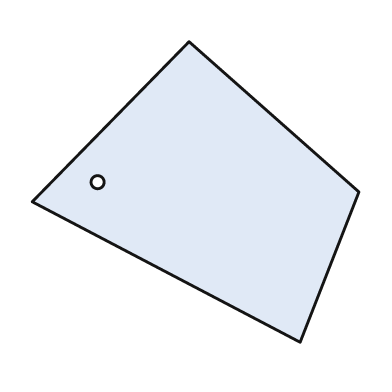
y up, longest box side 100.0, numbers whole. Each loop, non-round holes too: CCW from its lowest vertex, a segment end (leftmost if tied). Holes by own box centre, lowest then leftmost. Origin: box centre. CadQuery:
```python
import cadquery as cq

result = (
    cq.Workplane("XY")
    .moveTo(32.0, -46.0)
    .lineTo(50.0, 0.0)
    .lineTo(-2.0, 46.0)
    .lineTo(-50.0, -3.0)
    .close()
    .moveTo(-30.0, 3.0)
    .circle(2.0)
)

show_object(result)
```